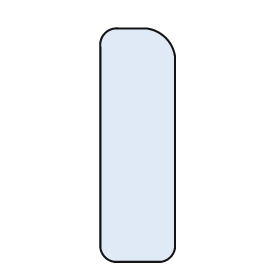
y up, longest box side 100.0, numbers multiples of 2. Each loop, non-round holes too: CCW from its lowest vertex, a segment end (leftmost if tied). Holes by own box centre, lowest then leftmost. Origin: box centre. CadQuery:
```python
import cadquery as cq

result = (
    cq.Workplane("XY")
    .moveTo(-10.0, -50.0)
    .lineTo(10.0, -50.0)
    .threePointArc((14.0, -48.0), (16.0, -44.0))
    .lineTo(16.0, 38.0)
    .threePointArc((12.0, 46.0), (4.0, 50.0))
    .lineTo(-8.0, 50.0)
    .threePointArc((-14.0, 48.0), (-16.0, 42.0))
    .lineTo(-16.0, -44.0)
    .threePointArc((-14.0, -48.0), (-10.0, -50.0))
    .close()
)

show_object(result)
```